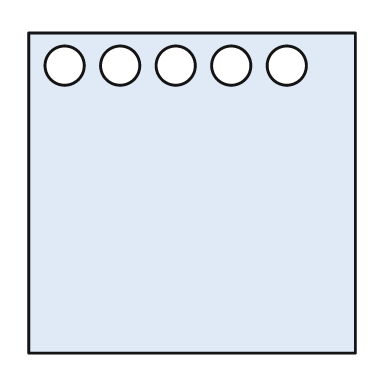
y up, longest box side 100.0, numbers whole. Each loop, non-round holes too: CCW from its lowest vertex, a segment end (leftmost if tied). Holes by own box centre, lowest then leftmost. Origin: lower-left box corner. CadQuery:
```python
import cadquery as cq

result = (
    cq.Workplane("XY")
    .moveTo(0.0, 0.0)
    .lineTo(100.0, 0.0)
    .lineTo(100.0, 98.0)
    .lineTo(0.0, 98.0)
    .close()
    .moveTo(11.0, 88.0)
    .circle(6.0)
    .moveTo(28.0, 88.0)
    .circle(6.0)
    .moveTo(45.0, 88.0)
    .circle(6.0)
    .moveTo(62.0, 88.0)
    .circle(6.0)
    .moveTo(79.0, 88.0)
    .circle(6.0)
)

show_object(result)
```